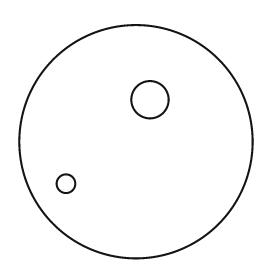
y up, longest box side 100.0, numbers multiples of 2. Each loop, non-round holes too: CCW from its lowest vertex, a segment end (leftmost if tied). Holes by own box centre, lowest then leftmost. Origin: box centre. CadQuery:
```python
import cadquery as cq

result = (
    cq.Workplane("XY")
    .moveTo(0.0, 0.0)
    .circle(50.0)
    .moveTo(-30.0, -18.0)
    .circle(4.0)
    .moveTo(6.0, 18.0)
    .circle(8.0)
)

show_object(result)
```